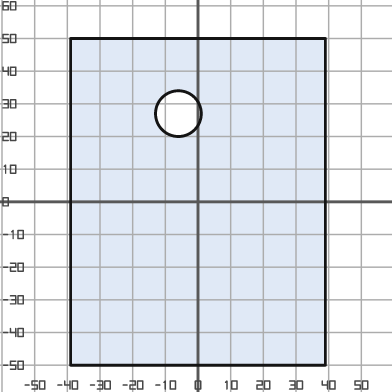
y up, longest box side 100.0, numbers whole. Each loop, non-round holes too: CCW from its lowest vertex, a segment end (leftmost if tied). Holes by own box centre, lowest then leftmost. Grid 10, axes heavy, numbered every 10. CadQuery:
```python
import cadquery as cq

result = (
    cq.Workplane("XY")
    .moveTo(-39.0, -50.0)
    .lineTo(39.0, -50.0)
    .lineTo(39.0, 50.0)
    .lineTo(-39.0, 50.0)
    .close()
    .moveTo(-6.0, 27.0)
    .circle(7.0)
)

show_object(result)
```